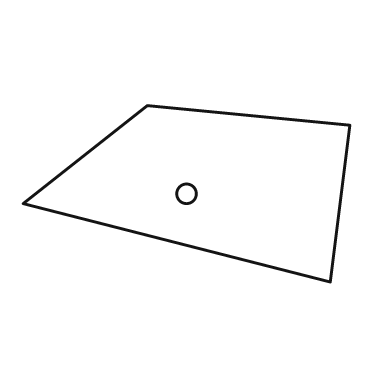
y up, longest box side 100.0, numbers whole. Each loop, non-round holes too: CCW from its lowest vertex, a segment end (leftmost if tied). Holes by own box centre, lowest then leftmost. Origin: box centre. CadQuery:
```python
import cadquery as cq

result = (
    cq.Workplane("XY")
    .moveTo(44.0, -27.0)
    .lineTo(50.0, 21.0)
    .lineTo(-12.0, 27.0)
    .lineTo(-50.0, -3.0)
    .close()
    .moveTo(0.0, 0.0)
    .circle(3.0)
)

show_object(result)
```